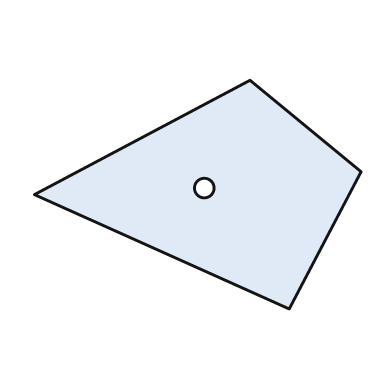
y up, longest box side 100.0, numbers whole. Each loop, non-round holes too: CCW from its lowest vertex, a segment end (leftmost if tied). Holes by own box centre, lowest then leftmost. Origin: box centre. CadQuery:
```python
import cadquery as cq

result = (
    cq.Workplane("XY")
    .moveTo(28.0, -35.0)
    .lineTo(50.0, 7.0)
    .lineTo(16.0, 35.0)
    .lineTo(-50.0, 0.0)
    .close()
    .moveTo(2.0, 2.0)
    .circle(3.0)
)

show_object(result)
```